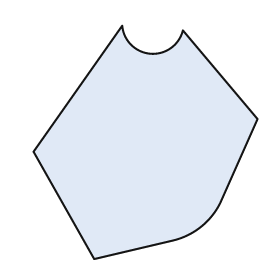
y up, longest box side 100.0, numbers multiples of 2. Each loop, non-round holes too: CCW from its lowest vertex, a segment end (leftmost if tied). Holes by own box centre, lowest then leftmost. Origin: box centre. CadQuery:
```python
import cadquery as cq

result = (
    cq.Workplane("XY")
    .moveTo(-22.0, -50.0)
    .lineTo(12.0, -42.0)
    .threePointArc((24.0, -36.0), (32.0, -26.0))
    .lineTo(48.0, 10.0)
    .lineTo(16.0, 48.0)
    .threePointArc((2.0, 38.0), (-10.0, 50.0))
    .lineTo(-48.0, -4.0)
    .close()
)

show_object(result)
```